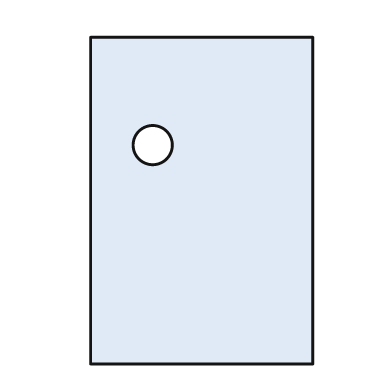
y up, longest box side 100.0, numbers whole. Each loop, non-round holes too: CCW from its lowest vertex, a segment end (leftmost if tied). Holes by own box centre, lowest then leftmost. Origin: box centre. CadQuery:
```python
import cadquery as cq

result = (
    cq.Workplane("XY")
    .moveTo(-34.0, -50.0)
    .lineTo(34.0, -50.0)
    .lineTo(34.0, 50.0)
    .lineTo(-34.0, 50.0)
    .close()
    .moveTo(-15.0, 17.0)
    .circle(6.0)
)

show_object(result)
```